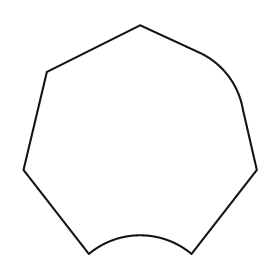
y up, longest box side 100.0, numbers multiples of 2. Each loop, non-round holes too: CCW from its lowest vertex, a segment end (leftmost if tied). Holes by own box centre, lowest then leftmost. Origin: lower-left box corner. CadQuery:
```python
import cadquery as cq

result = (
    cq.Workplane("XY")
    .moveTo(28.0, 0.0)
    .threePointArc((50.0, 8.0), (72.0, 0.0))
    .lineTo(100.0, 36.0)
    .lineTo(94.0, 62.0)
    .threePointArc((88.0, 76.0), (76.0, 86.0))
    .lineTo(50.0, 98.0)
    .lineTo(10.0, 78.0)
    .lineTo(0.0, 36.0)
    .close()
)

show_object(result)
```